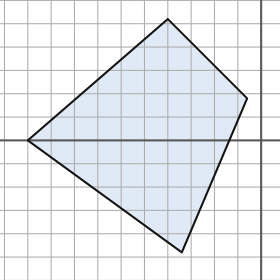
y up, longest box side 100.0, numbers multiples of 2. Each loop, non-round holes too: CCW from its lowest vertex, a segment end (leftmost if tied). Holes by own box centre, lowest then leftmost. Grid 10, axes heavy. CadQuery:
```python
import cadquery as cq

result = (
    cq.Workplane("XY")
    .moveTo(-34.0, -48.0)
    .lineTo(-6.0, 18.0)
    .lineTo(-40.0, 52.0)
    .lineTo(-100.0, 0.0)
    .close()
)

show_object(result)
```